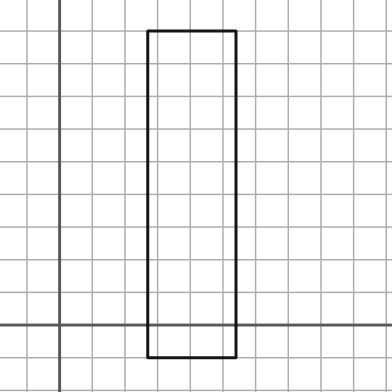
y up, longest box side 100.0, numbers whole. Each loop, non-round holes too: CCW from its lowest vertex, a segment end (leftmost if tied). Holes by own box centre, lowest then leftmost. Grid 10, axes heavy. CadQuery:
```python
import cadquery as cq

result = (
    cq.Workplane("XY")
    .moveTo(27.0, -10.0)
    .lineTo(54.0, -10.0)
    .lineTo(54.0, 90.0)
    .lineTo(27.0, 90.0)
    .close()
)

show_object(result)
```